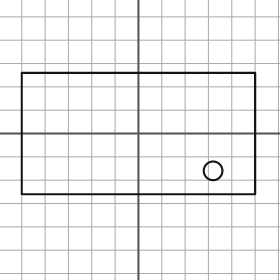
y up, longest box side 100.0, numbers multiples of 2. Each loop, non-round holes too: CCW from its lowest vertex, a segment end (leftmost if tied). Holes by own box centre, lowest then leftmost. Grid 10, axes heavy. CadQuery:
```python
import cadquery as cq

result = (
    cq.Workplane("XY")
    .moveTo(-50.0, -26.0)
    .lineTo(50.0, -26.0)
    .lineTo(50.0, 26.0)
    .lineTo(-50.0, 26.0)
    .close()
    .moveTo(32.0, -16.0)
    .circle(4.0)
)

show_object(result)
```